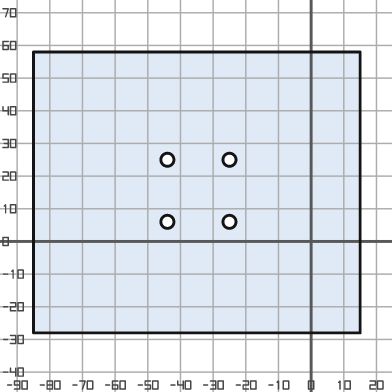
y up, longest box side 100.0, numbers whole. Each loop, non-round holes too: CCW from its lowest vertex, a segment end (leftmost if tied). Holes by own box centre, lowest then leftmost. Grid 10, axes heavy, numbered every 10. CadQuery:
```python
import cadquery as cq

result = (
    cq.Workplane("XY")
    .moveTo(-85.0, -28.0)
    .lineTo(15.0, -28.0)
    .lineTo(15.0, 58.0)
    .lineTo(-85.0, 58.0)
    .close()
    .moveTo(-44.0, 6.0)
    .circle(2.0)
    .moveTo(-25.0, 6.0)
    .circle(2.0)
    .moveTo(-44.0, 25.0)
    .circle(2.0)
    .moveTo(-25.0, 25.0)
    .circle(2.0)
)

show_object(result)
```